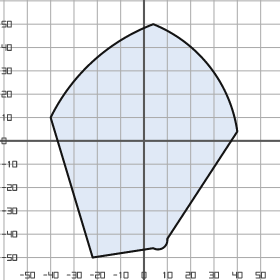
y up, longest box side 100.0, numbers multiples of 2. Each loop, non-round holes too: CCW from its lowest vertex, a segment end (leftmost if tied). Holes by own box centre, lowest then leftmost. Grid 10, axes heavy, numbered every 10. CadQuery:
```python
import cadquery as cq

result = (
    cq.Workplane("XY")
    .moveTo(-22.0, -50.0)
    .lineTo(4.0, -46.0)
    .threePointArc((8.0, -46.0), (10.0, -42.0))
    .lineTo(40.0, 4.0)
    .threePointArc((28.0, 32.0), (4.0, 50.0))
    .threePointArc((-22.0, 34.0), (-40.0, 10.0))
    .close()
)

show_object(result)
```